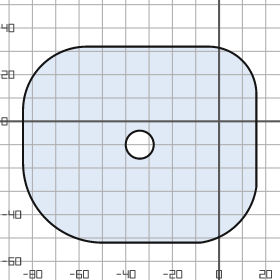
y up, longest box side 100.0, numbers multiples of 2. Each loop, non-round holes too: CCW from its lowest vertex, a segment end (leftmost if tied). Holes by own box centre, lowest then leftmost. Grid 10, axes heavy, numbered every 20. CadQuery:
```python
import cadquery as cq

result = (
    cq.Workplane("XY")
    .moveTo(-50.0, -52.0)
    .lineTo(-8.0, -52.0)
    .threePointArc((8.0, -44.0), (16.0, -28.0))
    .lineTo(16.0, 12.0)
    .threePointArc((10.0, 26.0), (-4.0, 32.0))
    .lineTo(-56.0, 32.0)
    .threePointArc((-76.0, 24.0), (-84.0, 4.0))
    .lineTo(-84.0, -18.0)
    .threePointArc((-74.0, -42.0), (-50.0, -52.0))
    .close()
    .moveTo(-34.0, -10.0)
    .circle(6.0)
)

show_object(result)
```